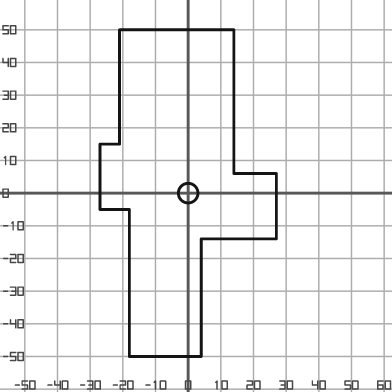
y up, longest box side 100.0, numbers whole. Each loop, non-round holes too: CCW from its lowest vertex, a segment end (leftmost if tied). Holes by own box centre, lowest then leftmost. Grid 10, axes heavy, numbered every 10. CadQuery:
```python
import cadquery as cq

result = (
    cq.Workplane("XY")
    .moveTo(-18.0, -50.0)
    .lineTo(4.0, -50.0)
    .lineTo(4.0, -14.0)
    .lineTo(27.0, -14.0)
    .lineTo(27.0, 6.0)
    .lineTo(14.0, 6.0)
    .lineTo(14.0, 50.0)
    .lineTo(-21.0, 50.0)
    .lineTo(-21.0, 15.0)
    .lineTo(-27.0, 15.0)
    .lineTo(-27.0, -5.0)
    .lineTo(-18.0, -5.0)
    .close()
    .moveTo(0.0, 0.0)
    .circle(3.0)
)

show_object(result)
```